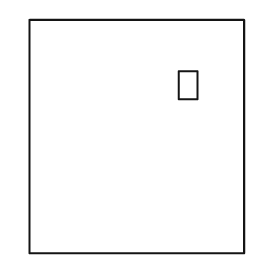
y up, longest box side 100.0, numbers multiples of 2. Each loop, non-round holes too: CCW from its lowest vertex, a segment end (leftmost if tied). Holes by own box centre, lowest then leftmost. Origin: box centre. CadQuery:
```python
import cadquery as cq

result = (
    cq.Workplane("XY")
    .moveTo(-46.0, -50.0)
    .lineTo(46.0, -50.0)
    .lineTo(46.0, 50.0)
    .lineTo(-46.0, 50.0)
    .close()
    .moveTo(18.0, 16.0)
    .lineTo(26.0, 16.0)
    .lineTo(26.0, 28.0)
    .lineTo(18.0, 28.0)
    .close()
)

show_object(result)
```